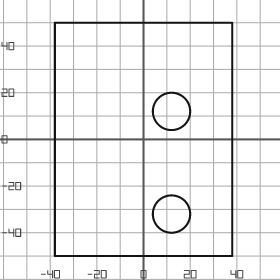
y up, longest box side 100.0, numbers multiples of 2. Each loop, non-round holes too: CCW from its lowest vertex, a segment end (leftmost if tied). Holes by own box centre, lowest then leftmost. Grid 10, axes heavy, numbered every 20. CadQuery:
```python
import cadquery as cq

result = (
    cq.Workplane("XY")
    .moveTo(-38.0, -50.0)
    .lineTo(38.0, -50.0)
    .lineTo(38.0, 50.0)
    .lineTo(-38.0, 50.0)
    .close()
    .moveTo(12.0, -32.0)
    .circle(8.0)
    .moveTo(12.0, 12.0)
    .circle(8.0)
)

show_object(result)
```